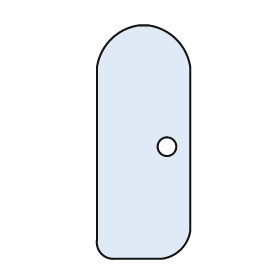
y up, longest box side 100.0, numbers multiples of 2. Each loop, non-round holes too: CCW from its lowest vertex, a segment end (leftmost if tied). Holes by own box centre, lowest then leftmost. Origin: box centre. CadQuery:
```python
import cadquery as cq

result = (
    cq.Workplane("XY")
    .moveTo(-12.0, -50.0)
    .lineTo(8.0, -50.0)
    .threePointArc((16.0, -46.0), (20.0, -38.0))
    .lineTo(20.0, 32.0)
    .threePointArc((14.0, 44.0), (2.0, 50.0))
    .lineTo(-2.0, 50.0)
    .threePointArc((-14.0, 44.0), (-20.0, 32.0))
    .lineTo(-20.0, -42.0)
    .threePointArc((-18.0, -48.0), (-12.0, -50.0))
    .close()
    .moveTo(10.0, -2.0)
    .circle(4.0)
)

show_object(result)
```